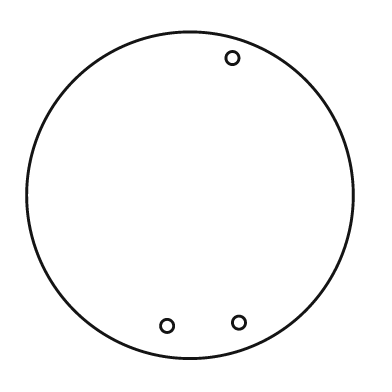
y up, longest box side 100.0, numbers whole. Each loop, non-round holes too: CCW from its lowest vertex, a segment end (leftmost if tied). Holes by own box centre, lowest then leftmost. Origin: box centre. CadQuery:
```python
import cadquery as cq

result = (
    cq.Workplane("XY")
    .moveTo(0.0, 0.0)
    .circle(50.0)
    .moveTo(-7.0, -40.0)
    .circle(2.0)
    .moveTo(15.0, -39.0)
    .circle(2.0)
    .moveTo(13.0, 42.0)
    .circle(2.0)
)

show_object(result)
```